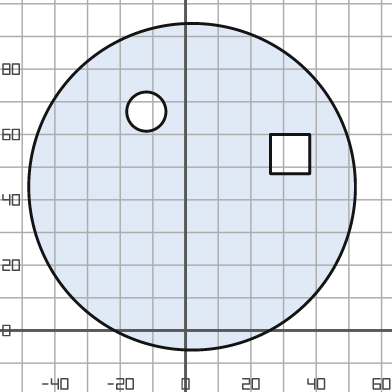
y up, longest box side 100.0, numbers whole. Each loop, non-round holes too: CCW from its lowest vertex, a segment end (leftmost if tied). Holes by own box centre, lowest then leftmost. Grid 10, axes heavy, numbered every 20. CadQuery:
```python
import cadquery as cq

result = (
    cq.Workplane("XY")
    .moveTo(2.0, 44.0)
    .circle(50.0)
    .moveTo(26.0, 48.0)
    .lineTo(38.0, 48.0)
    .lineTo(38.0, 60.0)
    .lineTo(26.0, 60.0)
    .close()
    .moveTo(-12.0, 67.0)
    .circle(6.0)
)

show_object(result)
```